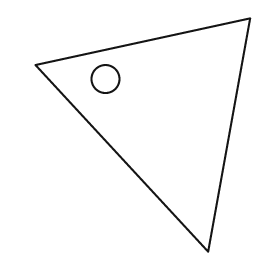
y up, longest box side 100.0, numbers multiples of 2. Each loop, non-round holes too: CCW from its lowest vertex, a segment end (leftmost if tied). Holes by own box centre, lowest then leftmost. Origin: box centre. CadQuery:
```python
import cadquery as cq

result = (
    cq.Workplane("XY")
    .moveTo(28.0, -50.0)
    .lineTo(46.0, 50.0)
    .lineTo(-46.0, 30.0)
    .close()
    .moveTo(-16.0, 24.0)
    .circle(6.0)
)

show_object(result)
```